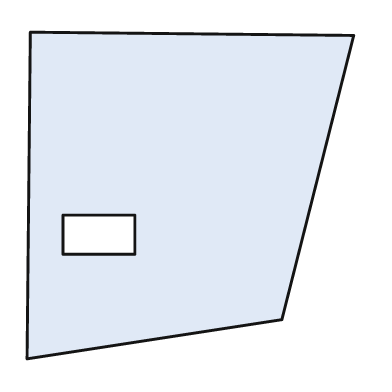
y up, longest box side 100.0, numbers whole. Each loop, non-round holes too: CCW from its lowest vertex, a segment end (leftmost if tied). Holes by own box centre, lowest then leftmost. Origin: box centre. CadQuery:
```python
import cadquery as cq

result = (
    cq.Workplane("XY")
    .moveTo(-50.0, -50.0)
    .lineTo(28.0, -38.0)
    .lineTo(50.0, 49.0)
    .lineTo(-49.0, 50.0)
    .close()
    .moveTo(-39.0, -18.0)
    .lineTo(-17.0, -18.0)
    .lineTo(-17.0, -6.0)
    .lineTo(-39.0, -6.0)
    .close()
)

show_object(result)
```